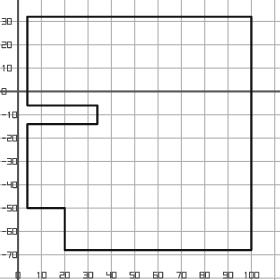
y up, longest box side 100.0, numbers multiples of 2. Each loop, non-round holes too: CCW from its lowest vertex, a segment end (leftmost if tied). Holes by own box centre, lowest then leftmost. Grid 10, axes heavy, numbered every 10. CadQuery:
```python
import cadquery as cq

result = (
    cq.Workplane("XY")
    .moveTo(20.0, -68.0)
    .lineTo(100.0, -68.0)
    .lineTo(100.0, 32.0)
    .lineTo(4.0, 32.0)
    .lineTo(4.0, -6.0)
    .lineTo(34.0, -6.0)
    .lineTo(34.0, -14.0)
    .lineTo(4.0, -14.0)
    .lineTo(4.0, -50.0)
    .lineTo(20.0, -50.0)
    .close()
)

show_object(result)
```